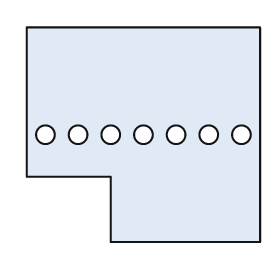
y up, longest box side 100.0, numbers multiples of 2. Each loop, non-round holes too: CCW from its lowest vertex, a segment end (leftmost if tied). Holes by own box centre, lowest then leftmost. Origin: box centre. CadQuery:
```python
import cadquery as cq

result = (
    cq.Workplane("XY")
    .moveTo(-14.0, -46.0)
    .lineTo(50.0, -46.0)
    .lineTo(50.0, 46.0)
    .lineTo(-50.0, 46.0)
    .lineTo(-50.0, -18.0)
    .lineTo(-14.0, -18.0)
    .close()
    .moveTo(-42.0, 0.0)
    .circle(4.0)
    .moveTo(-28.0, 0.0)
    .circle(4.0)
    .moveTo(-14.0, 0.0)
    .circle(4.0)
    .moveTo(0.0, 0.0)
    .circle(4.0)
    .moveTo(14.0, 0.0)
    .circle(4.0)
    .moveTo(28.0, 0.0)
    .circle(4.0)
    .moveTo(42.0, 0.0)
    .circle(4.0)
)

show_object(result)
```